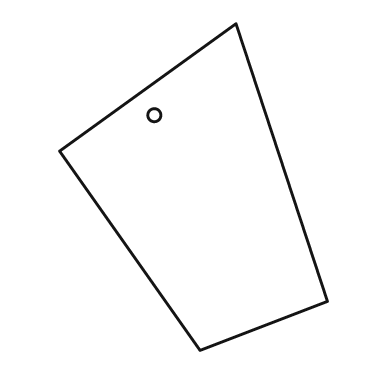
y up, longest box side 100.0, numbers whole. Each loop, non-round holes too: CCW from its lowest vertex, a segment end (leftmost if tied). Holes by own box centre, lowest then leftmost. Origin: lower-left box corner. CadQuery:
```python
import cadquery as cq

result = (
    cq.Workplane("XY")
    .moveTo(43.0, 0.0)
    .lineTo(82.0, 15.0)
    .lineTo(54.0, 100.0)
    .lineTo(0.0, 61.0)
    .close()
    .moveTo(29.0, 72.0)
    .circle(2.0)
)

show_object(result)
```